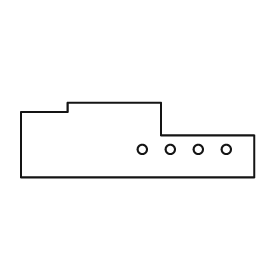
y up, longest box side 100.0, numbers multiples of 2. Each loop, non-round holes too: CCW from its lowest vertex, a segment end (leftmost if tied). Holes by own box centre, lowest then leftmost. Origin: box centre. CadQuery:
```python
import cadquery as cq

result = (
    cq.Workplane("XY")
    .moveTo(-50.0, -16.0)
    .lineTo(50.0, -16.0)
    .lineTo(50.0, 2.0)
    .lineTo(10.0, 2.0)
    .lineTo(10.0, 16.0)
    .lineTo(-30.0, 16.0)
    .lineTo(-30.0, 12.0)
    .lineTo(-50.0, 12.0)
    .close()
    .moveTo(2.0, -4.0)
    .circle(2.0)
    .moveTo(14.0, -4.0)
    .circle(2.0)
    .moveTo(26.0, -4.0)
    .circle(2.0)
    .moveTo(38.0, -4.0)
    .circle(2.0)
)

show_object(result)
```